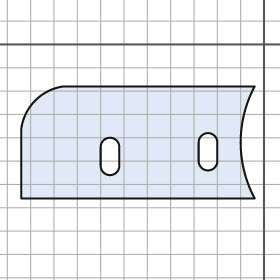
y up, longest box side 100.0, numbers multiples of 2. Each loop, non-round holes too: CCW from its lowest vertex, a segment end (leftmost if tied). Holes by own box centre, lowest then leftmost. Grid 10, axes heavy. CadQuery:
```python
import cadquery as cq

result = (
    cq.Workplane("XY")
    .moveTo(-104.0, -66.0)
    .lineTo(-4.0, -66.0)
    .threePointArc((-10.0, -42.0), (-4.0, -18.0))
    .lineTo(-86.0, -18.0)
    .threePointArc((-98.0, -24.0), (-104.0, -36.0))
    .close()
    .moveTo(-70.0, -52.0)
    .threePointArc((-66.0, -56.0), (-62.0, -52.0))
    .lineTo(-62.0, -44.0)
    .threePointArc((-66.0, -40.0), (-70.0, -44.0))
    .close()
    .moveTo(-28.0, -50.0)
    .threePointArc((-24.0, -54.0), (-20.0, -50.0))
    .lineTo(-20.0, -42.0)
    .threePointArc((-24.0, -38.0), (-28.0, -42.0))
    .close()
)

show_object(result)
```